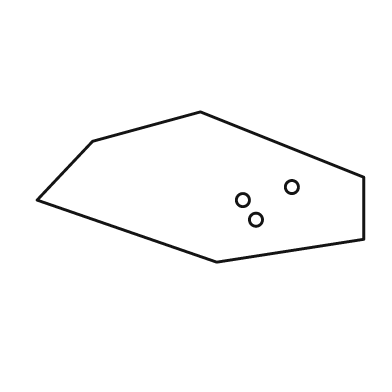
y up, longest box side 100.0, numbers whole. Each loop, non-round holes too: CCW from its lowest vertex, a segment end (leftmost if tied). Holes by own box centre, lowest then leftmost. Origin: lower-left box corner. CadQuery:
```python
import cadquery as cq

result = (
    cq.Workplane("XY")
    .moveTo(55.0, 0.0)
    .lineTo(100.0, 7.0)
    .lineTo(100.0, 26.0)
    .lineTo(50.0, 46.0)
    .lineTo(17.0, 37.0)
    .lineTo(0.0, 19.0)
    .close()
    .moveTo(67.0, 13.0)
    .circle(2.0)
    .moveTo(63.0, 19.0)
    .circle(2.0)
    .moveTo(78.0, 23.0)
    .circle(2.0)
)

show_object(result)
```